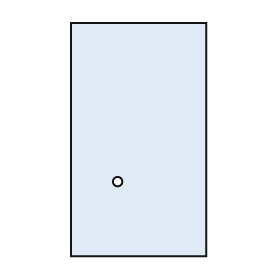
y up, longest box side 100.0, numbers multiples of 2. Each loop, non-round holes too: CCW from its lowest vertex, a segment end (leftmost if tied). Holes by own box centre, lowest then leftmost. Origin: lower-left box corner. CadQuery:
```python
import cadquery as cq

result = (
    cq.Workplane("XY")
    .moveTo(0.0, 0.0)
    .lineTo(58.0, 0.0)
    .lineTo(58.0, 100.0)
    .lineTo(0.0, 100.0)
    .close()
    .moveTo(20.0, 32.0)
    .circle(2.0)
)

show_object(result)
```